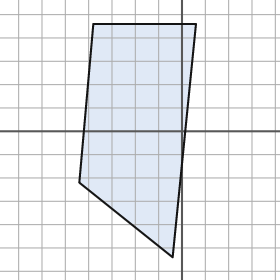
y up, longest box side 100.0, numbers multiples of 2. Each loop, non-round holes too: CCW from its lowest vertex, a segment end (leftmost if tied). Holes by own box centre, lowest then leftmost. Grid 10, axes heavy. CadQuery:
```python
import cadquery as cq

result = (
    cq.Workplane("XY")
    .moveTo(-4.0, -54.0)
    .lineTo(6.0, 46.0)
    .lineTo(-38.0, 46.0)
    .lineTo(-44.0, -22.0)
    .close()
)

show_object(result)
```